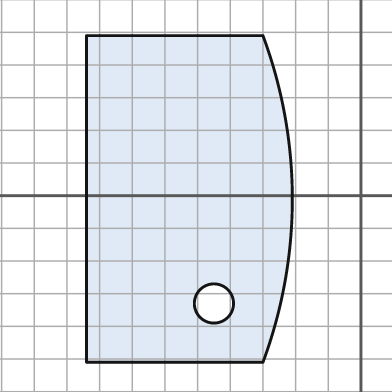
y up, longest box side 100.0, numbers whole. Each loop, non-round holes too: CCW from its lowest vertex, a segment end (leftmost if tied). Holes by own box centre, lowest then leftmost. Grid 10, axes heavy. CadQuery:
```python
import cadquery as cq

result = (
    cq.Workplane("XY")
    .moveTo(-84.0, -51.0)
    .lineTo(-30.0, -51.0)
    .threePointArc((-21.0, -1.0), (-30.0, 49.0))
    .lineTo(-84.0, 49.0)
    .close()
    .moveTo(-45.0, -33.0)
    .circle(6.0)
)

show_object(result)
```